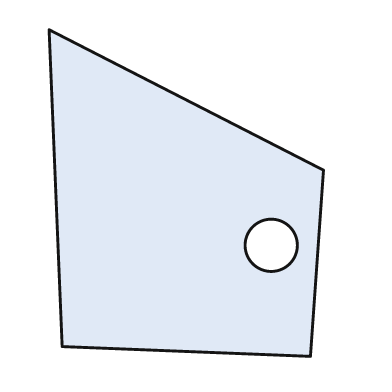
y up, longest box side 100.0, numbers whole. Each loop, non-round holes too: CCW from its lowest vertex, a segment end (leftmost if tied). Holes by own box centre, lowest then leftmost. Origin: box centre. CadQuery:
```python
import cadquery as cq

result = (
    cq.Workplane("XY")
    .moveTo(38.0, -50.0)
    .lineTo(42.0, 7.0)
    .lineTo(-42.0, 50.0)
    .lineTo(-38.0, -47.0)
    .close()
    .moveTo(26.0, -16.0)
    .circle(8.0)
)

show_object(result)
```